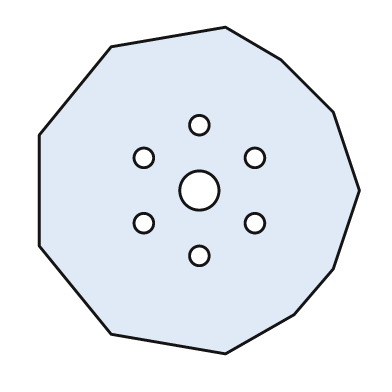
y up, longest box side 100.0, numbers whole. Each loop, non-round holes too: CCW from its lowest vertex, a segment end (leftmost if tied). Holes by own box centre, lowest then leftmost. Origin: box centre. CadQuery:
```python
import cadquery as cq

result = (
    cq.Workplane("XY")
    .moveTo(8.0, -50.0)
    .lineTo(29.0, -38.0)
    .lineTo(41.0, -24.0)
    .lineTo(49.0, 0.0)
    .lineTo(41.0, 24.0)
    .lineTo(25.0, 40.0)
    .lineTo(8.0, 50.0)
    .lineTo(-27.0, 44.0)
    .lineTo(-49.0, 17.0)
    .lineTo(-49.0, -17.0)
    .lineTo(-27.0, -44.0)
    .close()
    .moveTo(0.0, -20.0)
    .circle(3.0)
    .moveTo(-17.0, -10.0)
    .circle(3.0)
    .moveTo(17.0, -10.0)
    .circle(3.0)
    .moveTo(0.0, 0.0)
    .circle(6.0)
    .moveTo(-17.0, 10.0)
    .circle(3.0)
    .moveTo(17.0, 10.0)
    .circle(3.0)
    .moveTo(0.0, 20.0)
    .circle(3.0)
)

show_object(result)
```